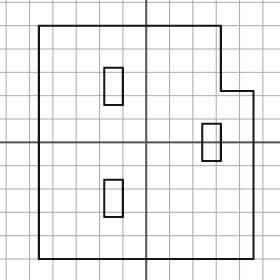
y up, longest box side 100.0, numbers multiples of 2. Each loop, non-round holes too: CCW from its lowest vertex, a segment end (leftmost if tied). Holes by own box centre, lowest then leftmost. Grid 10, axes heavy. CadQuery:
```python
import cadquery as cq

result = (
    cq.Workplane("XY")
    .moveTo(-46.0, -50.0)
    .lineTo(46.0, -50.0)
    .lineTo(46.0, 22.0)
    .lineTo(32.0, 22.0)
    .lineTo(32.0, 50.0)
    .lineTo(-46.0, 50.0)
    .close()
    .moveTo(-18.0, -32.0)
    .lineTo(-10.0, -32.0)
    .lineTo(-10.0, -16.0)
    .lineTo(-18.0, -16.0)
    .close()
    .moveTo(24.0, -8.0)
    .lineTo(32.0, -8.0)
    .lineTo(32.0, 8.0)
    .lineTo(24.0, 8.0)
    .close()
    .moveTo(-18.0, 16.0)
    .lineTo(-10.0, 16.0)
    .lineTo(-10.0, 32.0)
    .lineTo(-18.0, 32.0)
    .close()
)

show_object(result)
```